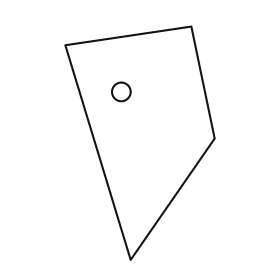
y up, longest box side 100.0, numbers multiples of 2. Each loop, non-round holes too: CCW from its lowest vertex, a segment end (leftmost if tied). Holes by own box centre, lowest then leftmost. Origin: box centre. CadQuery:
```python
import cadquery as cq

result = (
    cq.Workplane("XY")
    .moveTo(-4.0, -50.0)
    .lineTo(32.0, 2.0)
    .lineTo(22.0, 50.0)
    .lineTo(-32.0, 42.0)
    .close()
    .moveTo(-8.0, 22.0)
    .circle(4.0)
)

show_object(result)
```